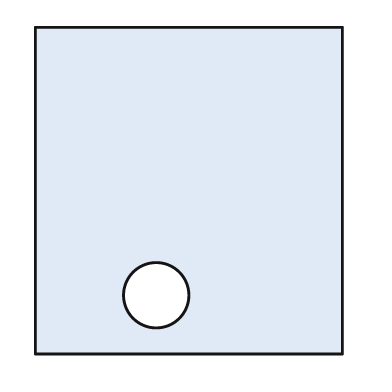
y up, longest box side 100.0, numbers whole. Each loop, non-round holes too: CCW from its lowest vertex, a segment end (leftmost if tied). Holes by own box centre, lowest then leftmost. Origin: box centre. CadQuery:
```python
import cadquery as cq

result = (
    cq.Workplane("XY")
    .moveTo(-47.0, -50.0)
    .lineTo(47.0, -50.0)
    .lineTo(47.0, 50.0)
    .lineTo(-47.0, 50.0)
    .close()
    .moveTo(-10.0, -32.0)
    .circle(10.0)
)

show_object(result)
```